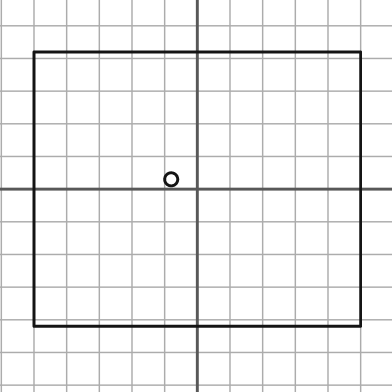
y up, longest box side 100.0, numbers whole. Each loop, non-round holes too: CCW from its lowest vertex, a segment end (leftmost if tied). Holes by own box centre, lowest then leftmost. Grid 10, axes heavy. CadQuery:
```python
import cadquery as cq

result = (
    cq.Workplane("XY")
    .moveTo(-50.0, -42.0)
    .lineTo(50.0, -42.0)
    .lineTo(50.0, 42.0)
    .lineTo(-50.0, 42.0)
    .close()
    .moveTo(-8.0, 3.0)
    .circle(2.0)
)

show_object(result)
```